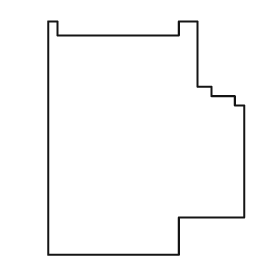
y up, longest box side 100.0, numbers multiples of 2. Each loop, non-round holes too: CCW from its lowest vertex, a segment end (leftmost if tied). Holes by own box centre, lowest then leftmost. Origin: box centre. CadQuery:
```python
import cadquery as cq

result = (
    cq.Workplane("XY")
    .moveTo(-42.0, -50.0)
    .lineTo(14.0, -50.0)
    .lineTo(14.0, -34.0)
    .lineTo(42.0, -34.0)
    .lineTo(42.0, 14.0)
    .lineTo(38.0, 14.0)
    .lineTo(38.0, 18.0)
    .lineTo(28.0, 18.0)
    .lineTo(28.0, 22.0)
    .lineTo(22.0, 22.0)
    .lineTo(22.0, 50.0)
    .lineTo(14.0, 50.0)
    .lineTo(14.0, 44.0)
    .lineTo(-38.0, 44.0)
    .lineTo(-38.0, 50.0)
    .lineTo(-42.0, 50.0)
    .close()
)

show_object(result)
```